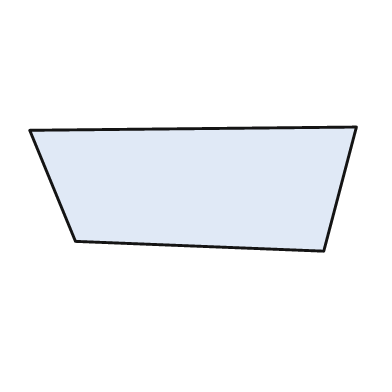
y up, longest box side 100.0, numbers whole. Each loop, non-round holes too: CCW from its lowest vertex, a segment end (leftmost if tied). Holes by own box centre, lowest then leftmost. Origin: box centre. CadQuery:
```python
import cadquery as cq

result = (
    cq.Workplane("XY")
    .moveTo(40.0, -19.0)
    .lineTo(50.0, 19.0)
    .lineTo(-50.0, 18.0)
    .lineTo(-36.0, -16.0)
    .close()
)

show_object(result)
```